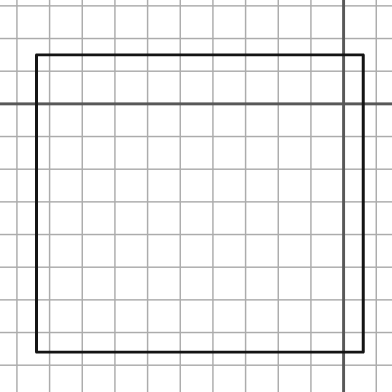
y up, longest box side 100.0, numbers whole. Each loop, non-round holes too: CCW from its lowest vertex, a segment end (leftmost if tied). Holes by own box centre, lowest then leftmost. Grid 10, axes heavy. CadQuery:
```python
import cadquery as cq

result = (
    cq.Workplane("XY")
    .moveTo(-94.0, -76.0)
    .lineTo(6.0, -76.0)
    .lineTo(6.0, 15.0)
    .lineTo(-94.0, 15.0)
    .close()
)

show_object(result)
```